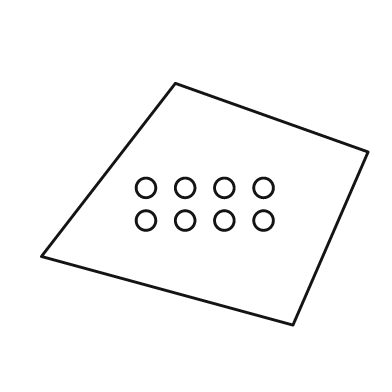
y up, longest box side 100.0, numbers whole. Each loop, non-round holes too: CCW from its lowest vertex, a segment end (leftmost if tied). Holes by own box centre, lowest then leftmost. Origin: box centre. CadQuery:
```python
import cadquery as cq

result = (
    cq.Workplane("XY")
    .moveTo(27.0, -37.0)
    .lineTo(50.0, 16.0)
    .lineTo(-9.0, 37.0)
    .lineTo(-50.0, -16.0)
    .close()
    .moveTo(-18.0, -5.0)
    .circle(3.0)
    .moveTo(-6.0, -5.0)
    .circle(3.0)
    .moveTo(6.0, -5.0)
    .circle(3.0)
    .moveTo(18.0, -5.0)
    .circle(3.0)
    .moveTo(-18.0, 5.0)
    .circle(3.0)
    .moveTo(-6.0, 5.0)
    .circle(3.0)
    .moveTo(6.0, 5.0)
    .circle(3.0)
    .moveTo(18.0, 5.0)
    .circle(3.0)
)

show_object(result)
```